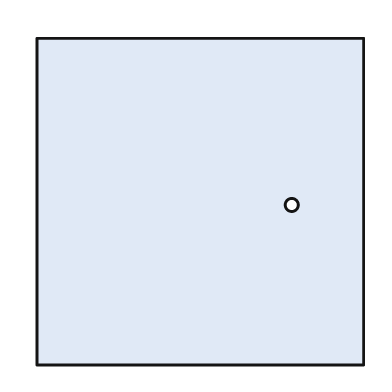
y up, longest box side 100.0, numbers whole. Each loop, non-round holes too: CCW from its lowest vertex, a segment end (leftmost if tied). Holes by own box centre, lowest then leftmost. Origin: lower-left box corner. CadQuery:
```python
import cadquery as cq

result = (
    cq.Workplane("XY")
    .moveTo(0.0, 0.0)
    .lineTo(100.0, 0.0)
    .lineTo(100.0, 100.0)
    .lineTo(0.0, 100.0)
    .close()
    .moveTo(78.0, 49.0)
    .circle(2.0)
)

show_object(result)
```